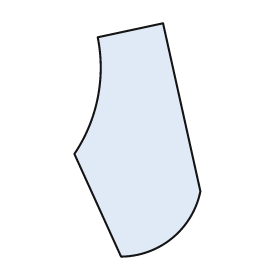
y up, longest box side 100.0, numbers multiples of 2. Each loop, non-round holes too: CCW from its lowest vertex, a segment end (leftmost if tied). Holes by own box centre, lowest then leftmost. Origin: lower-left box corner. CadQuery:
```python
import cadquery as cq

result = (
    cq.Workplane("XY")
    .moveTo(20.0, 0.0)
    .threePointArc((42.0, 8.0), (54.0, 28.0))
    .lineTo(38.0, 100.0)
    .lineTo(10.0, 94.0)
    .threePointArc((10.0, 68.0), (0.0, 44.0))
    .close()
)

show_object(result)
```